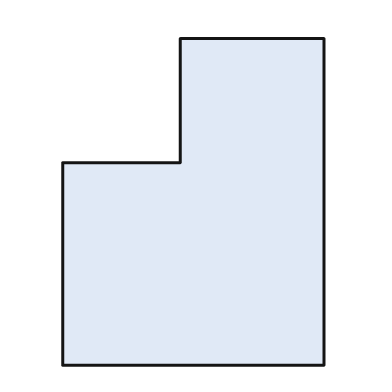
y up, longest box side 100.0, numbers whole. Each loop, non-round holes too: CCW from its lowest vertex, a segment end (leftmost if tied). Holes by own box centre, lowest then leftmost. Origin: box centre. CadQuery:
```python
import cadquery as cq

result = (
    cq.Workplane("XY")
    .moveTo(-40.0, -50.0)
    .lineTo(40.0, -50.0)
    .lineTo(40.0, 50.0)
    .lineTo(-4.0, 50.0)
    .lineTo(-4.0, 12.0)
    .lineTo(-40.0, 12.0)
    .close()
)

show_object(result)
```